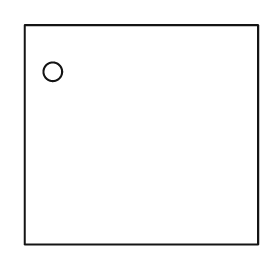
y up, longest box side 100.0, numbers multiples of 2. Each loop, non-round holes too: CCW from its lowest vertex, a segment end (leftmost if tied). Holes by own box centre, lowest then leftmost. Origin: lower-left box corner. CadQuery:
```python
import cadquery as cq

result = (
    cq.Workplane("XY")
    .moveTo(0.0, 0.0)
    .lineTo(100.0, 0.0)
    .lineTo(100.0, 94.0)
    .lineTo(0.0, 94.0)
    .close()
    .moveTo(12.0, 74.0)
    .circle(4.0)
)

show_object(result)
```